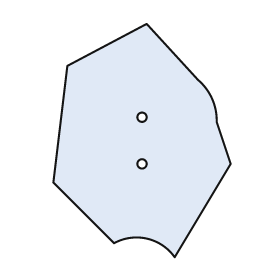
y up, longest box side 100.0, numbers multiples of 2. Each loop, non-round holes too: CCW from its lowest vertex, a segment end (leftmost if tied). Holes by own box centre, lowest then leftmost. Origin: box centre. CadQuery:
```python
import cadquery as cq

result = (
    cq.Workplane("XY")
    .moveTo(14.0, -50.0)
    .lineTo(38.0, -10.0)
    .lineTo(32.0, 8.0)
    .threePointArc((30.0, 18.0), (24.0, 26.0))
    .lineTo(2.0, 50.0)
    .lineTo(-32.0, 32.0)
    .lineTo(-38.0, -18.0)
    .lineTo(-12.0, -44.0)
    .threePointArc((2.0, -42.0), (14.0, -50.0))
    .close()
    .moveTo(0.0, -10.0)
    .circle(2.0)
    .moveTo(0.0, 10.0)
    .circle(2.0)
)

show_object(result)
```